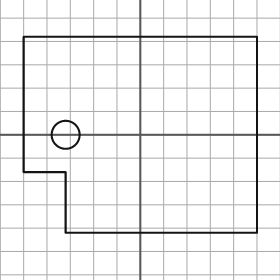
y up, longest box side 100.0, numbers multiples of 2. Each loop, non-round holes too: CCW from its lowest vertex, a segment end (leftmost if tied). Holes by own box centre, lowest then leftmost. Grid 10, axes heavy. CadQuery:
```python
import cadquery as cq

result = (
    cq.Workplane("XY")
    .moveTo(-32.0, -42.0)
    .lineTo(50.0, -42.0)
    .lineTo(50.0, 42.0)
    .lineTo(-50.0, 42.0)
    .lineTo(-50.0, -16.0)
    .lineTo(-32.0, -16.0)
    .close()
    .moveTo(-32.0, 0.0)
    .circle(6.0)
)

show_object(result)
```